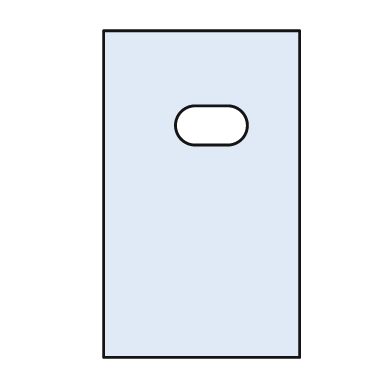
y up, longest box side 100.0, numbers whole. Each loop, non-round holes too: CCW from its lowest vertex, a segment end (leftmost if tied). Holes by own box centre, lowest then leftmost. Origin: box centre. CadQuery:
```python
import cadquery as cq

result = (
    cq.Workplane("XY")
    .moveTo(-30.0, -50.0)
    .lineTo(30.0, -50.0)
    .lineTo(30.0, 50.0)
    .lineTo(-30.0, 50.0)
    .close()
    .moveTo(-2.0, 15.0)
    .lineTo(8.0, 15.0)
    .threePointArc((14.0, 21.0), (8.0, 27.0))
    .lineTo(-2.0, 27.0)
    .threePointArc((-8.0, 21.0), (-2.0, 15.0))
    .close()
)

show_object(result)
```